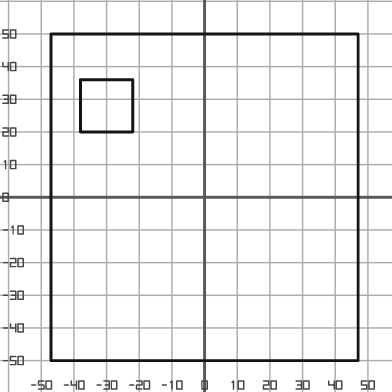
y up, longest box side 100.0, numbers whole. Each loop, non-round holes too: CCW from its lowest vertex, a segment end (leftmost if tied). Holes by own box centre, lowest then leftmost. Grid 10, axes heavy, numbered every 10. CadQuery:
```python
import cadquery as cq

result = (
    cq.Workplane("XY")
    .moveTo(-47.0, -50.0)
    .lineTo(47.0, -50.0)
    .lineTo(47.0, 50.0)
    .lineTo(-47.0, 50.0)
    .close()
    .moveTo(-38.0, 20.0)
    .lineTo(-22.0, 20.0)
    .lineTo(-22.0, 36.0)
    .lineTo(-38.0, 36.0)
    .close()
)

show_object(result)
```